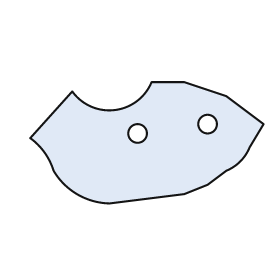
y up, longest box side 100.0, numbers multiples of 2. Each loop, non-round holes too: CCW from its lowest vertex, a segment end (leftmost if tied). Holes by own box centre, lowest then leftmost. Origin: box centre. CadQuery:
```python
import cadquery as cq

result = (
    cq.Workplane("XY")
    .moveTo(-16.0, -26.0)
    .lineTo(16.0, -22.0)
    .lineTo(26.0, -18.0)
    .lineTo(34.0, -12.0)
    .threePointArc((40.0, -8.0), (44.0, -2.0))
    .lineTo(50.0, 8.0)
    .lineTo(34.0, 20.0)
    .lineTo(16.0, 26.0)
    .lineTo(2.0, 26.0)
    .threePointArc((-14.0, 14.0), (-32.0, 22.0))
    .lineTo(-50.0, 2.0)
    .threePointArc((-44.0, -4.0), (-40.0, -12.0))
    .threePointArc((-30.0, -22.0), (-16.0, -26.0))
    .close()
    .moveTo(-4.0, 4.0)
    .circle(4.0)
    .moveTo(26.0, 8.0)
    .circle(4.0)
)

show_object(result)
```